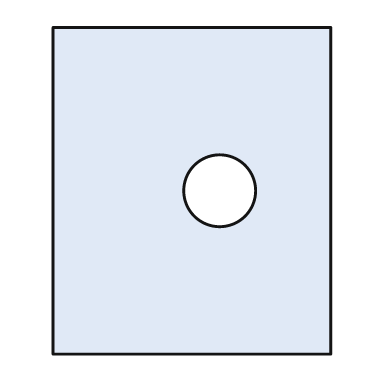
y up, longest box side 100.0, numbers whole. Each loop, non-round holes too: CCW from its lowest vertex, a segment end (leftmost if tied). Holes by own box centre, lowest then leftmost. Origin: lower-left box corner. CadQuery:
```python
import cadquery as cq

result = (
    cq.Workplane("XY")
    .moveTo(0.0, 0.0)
    .lineTo(85.0, 0.0)
    .lineTo(85.0, 100.0)
    .lineTo(0.0, 100.0)
    .close()
    .moveTo(51.0, 50.0)
    .circle(11.0)
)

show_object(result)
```